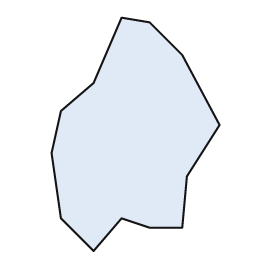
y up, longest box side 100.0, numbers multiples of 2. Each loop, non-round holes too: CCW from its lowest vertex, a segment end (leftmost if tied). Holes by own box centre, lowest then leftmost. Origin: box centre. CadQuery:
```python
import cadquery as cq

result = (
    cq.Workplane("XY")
    .moveTo(-18.0, -50.0)
    .lineTo(-6.0, -36.0)
    .lineTo(6.0, -40.0)
    .lineTo(20.0, -40.0)
    .lineTo(22.0, -18.0)
    .lineTo(36.0, 4.0)
    .lineTo(20.0, 34.0)
    .lineTo(6.0, 48.0)
    .lineTo(-6.0, 50.0)
    .lineTo(-18.0, 22.0)
    .lineTo(-32.0, 10.0)
    .lineTo(-36.0, -8.0)
    .lineTo(-32.0, -36.0)
    .close()
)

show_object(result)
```